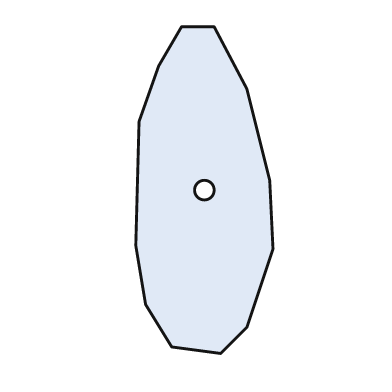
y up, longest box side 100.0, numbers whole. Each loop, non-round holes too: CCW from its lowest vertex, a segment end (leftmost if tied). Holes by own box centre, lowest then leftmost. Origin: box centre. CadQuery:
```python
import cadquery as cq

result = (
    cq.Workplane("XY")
    .moveTo(5.0, -50.0)
    .lineTo(13.0, -42.0)
    .lineTo(21.0, -18.0)
    .lineTo(20.0, 3.0)
    .lineTo(13.0, 31.0)
    .lineTo(3.0, 50.0)
    .lineTo(-7.0, 50.0)
    .lineTo(-14.0, 38.0)
    .lineTo(-20.0, 21.0)
    .lineTo(-21.0, -17.0)
    .lineTo(-18.0, -35.0)
    .lineTo(-10.0, -48.0)
    .close()
    .moveTo(0.0, 0.0)
    .circle(3.0)
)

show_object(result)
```